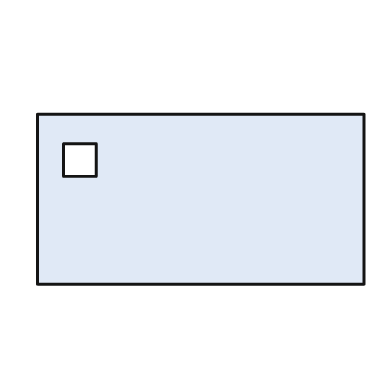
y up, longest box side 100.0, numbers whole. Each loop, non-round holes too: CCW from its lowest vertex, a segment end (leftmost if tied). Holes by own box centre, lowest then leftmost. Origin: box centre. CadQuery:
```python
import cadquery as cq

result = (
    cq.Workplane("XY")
    .moveTo(-50.0, -26.0)
    .lineTo(50.0, -26.0)
    .lineTo(50.0, 26.0)
    .lineTo(-50.0, 26.0)
    .close()
    .moveTo(-42.0, 7.0)
    .lineTo(-32.0, 7.0)
    .lineTo(-32.0, 17.0)
    .lineTo(-42.0, 17.0)
    .close()
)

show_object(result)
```